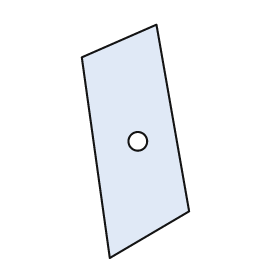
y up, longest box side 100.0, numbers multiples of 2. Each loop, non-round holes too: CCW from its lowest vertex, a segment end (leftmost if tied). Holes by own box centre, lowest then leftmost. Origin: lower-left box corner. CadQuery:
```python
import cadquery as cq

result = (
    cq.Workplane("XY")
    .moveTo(12.0, 0.0)
    .lineTo(46.0, 20.0)
    .lineTo(32.0, 100.0)
    .lineTo(0.0, 86.0)
    .close()
    .moveTo(24.0, 50.0)
    .circle(4.0)
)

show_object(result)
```